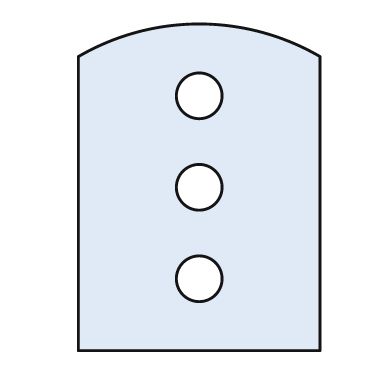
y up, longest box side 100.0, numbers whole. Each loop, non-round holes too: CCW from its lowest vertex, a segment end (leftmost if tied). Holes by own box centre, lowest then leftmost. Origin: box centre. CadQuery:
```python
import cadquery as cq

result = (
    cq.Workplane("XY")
    .moveTo(-37.0, -50.0)
    .lineTo(37.0, -50.0)
    .lineTo(37.0, 40.0)
    .threePointArc((0.0, 50.0), (-37.0, 40.0))
    .close()
    .moveTo(0.0, -28.0)
    .circle(7.0)
    .moveTo(0.0, 0.0)
    .circle(7.0)
    .moveTo(0.0, 28.0)
    .circle(7.0)
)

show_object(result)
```